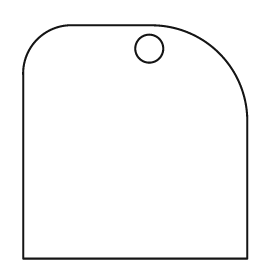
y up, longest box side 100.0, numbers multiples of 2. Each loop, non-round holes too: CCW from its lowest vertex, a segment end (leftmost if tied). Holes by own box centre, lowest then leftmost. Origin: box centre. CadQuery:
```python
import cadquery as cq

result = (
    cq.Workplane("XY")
    .moveTo(-48.0, -50.0)
    .lineTo(48.0, -50.0)
    .lineTo(48.0, 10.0)
    .threePointArc((36.0, 38.0), (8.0, 50.0))
    .lineTo(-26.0, 50.0)
    .threePointArc((-42.0, 44.0), (-48.0, 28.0))
    .close()
    .moveTo(6.0, 40.0)
    .circle(6.0)
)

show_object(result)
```